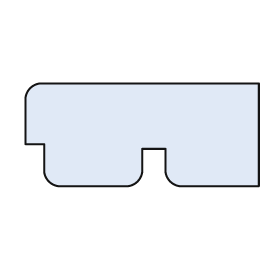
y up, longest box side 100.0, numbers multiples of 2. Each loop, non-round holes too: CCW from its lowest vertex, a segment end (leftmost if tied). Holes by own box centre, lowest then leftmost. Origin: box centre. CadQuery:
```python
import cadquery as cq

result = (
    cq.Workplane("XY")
    .moveTo(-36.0, -22.0)
    .lineTo(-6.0, -22.0)
    .threePointArc((-2.0, -20.0), (0.0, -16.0))
    .lineTo(0.0, -6.0)
    .lineTo(10.0, -6.0)
    .lineTo(10.0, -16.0)
    .threePointArc((12.0, -20.0), (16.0, -22.0))
    .lineTo(50.0, -22.0)
    .lineTo(50.0, 22.0)
    .lineTo(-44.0, 22.0)
    .threePointArc((-48.0, 20.0), (-50.0, 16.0))
    .lineTo(-50.0, -4.0)
    .lineTo(-42.0, -4.0)
    .lineTo(-42.0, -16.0)
    .threePointArc((-40.0, -20.0), (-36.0, -22.0))
    .close()
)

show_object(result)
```